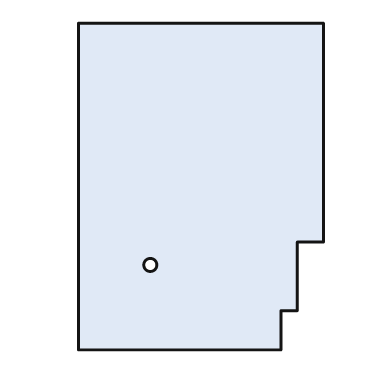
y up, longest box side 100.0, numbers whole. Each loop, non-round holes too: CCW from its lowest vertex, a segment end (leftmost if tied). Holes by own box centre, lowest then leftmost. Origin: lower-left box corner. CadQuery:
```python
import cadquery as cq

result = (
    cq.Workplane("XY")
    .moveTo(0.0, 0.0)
    .lineTo(62.0, 0.0)
    .lineTo(62.0, 12.0)
    .lineTo(67.0, 12.0)
    .lineTo(67.0, 33.0)
    .lineTo(75.0, 33.0)
    .lineTo(75.0, 100.0)
    .lineTo(0.0, 100.0)
    .close()
    .moveTo(22.0, 26.0)
    .circle(2.0)
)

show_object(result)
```